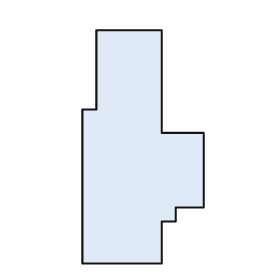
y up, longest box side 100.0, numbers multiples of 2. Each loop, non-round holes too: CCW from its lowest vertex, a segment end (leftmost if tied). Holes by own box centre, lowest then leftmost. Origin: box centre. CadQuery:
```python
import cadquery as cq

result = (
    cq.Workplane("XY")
    .moveTo(-26.0, -50.0)
    .lineTo(8.0, -50.0)
    .lineTo(8.0, -32.0)
    .lineTo(14.0, -32.0)
    .lineTo(14.0, -26.0)
    .lineTo(26.0, -26.0)
    .lineTo(26.0, 6.0)
    .lineTo(8.0, 6.0)
    .lineTo(8.0, 50.0)
    .lineTo(-20.0, 50.0)
    .lineTo(-20.0, 16.0)
    .lineTo(-26.0, 16.0)
    .close()
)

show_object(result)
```